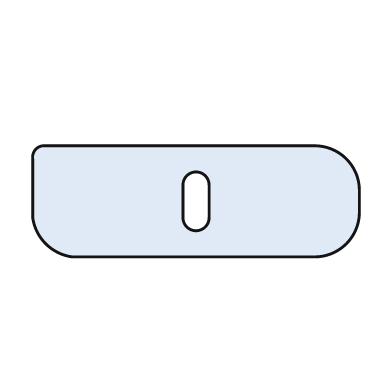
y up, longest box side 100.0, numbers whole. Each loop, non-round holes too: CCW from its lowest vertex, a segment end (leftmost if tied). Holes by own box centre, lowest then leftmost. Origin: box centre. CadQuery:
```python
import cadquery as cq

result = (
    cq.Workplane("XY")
    .moveTo(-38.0, -17.0)
    .lineTo(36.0, -17.0)
    .threePointArc((46.0, -13.0), (50.0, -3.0))
    .lineTo(50.0, 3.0)
    .threePointArc((46.0, 13.0), (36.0, 17.0))
    .lineTo(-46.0, 17.0)
    .threePointArc((-49.0, 16.0), (-50.0, 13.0))
    .lineTo(-50.0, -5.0)
    .threePointArc((-46.0, -13.0), (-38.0, -17.0))
    .close()
    .moveTo(-4.0, -5.0)
    .threePointArc((0.0, -9.0), (4.0, -5.0))
    .lineTo(4.0, 5.0)
    .threePointArc((0.0, 9.0), (-4.0, 5.0))
    .close()
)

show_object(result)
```